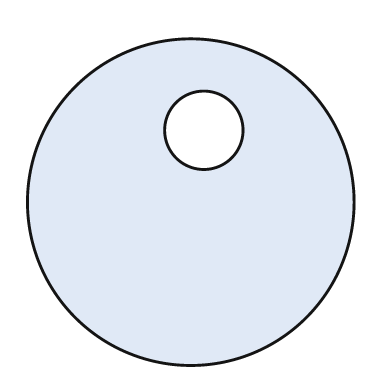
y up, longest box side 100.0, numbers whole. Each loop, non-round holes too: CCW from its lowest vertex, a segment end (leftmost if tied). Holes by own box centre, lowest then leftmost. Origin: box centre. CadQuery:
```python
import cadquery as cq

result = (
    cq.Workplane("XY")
    .moveTo(0.0, 0.0)
    .circle(50.0)
    .moveTo(4.0, 22.0)
    .circle(12.0)
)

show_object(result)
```